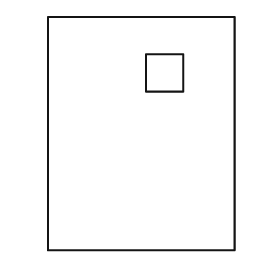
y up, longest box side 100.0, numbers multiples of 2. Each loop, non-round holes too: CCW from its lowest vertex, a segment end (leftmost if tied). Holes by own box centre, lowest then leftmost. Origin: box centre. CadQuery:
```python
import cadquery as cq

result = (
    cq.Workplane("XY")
    .moveTo(-40.0, -50.0)
    .lineTo(40.0, -50.0)
    .lineTo(40.0, 50.0)
    .lineTo(-40.0, 50.0)
    .close()
    .moveTo(2.0, 18.0)
    .lineTo(18.0, 18.0)
    .lineTo(18.0, 34.0)
    .lineTo(2.0, 34.0)
    .close()
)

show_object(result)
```